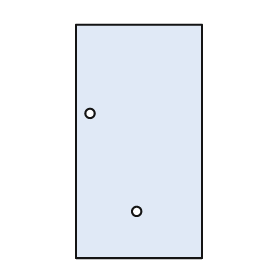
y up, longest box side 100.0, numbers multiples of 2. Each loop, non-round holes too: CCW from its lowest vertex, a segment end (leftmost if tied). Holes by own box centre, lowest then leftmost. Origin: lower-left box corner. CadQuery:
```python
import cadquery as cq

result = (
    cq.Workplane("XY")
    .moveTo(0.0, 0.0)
    .lineTo(54.0, 0.0)
    .lineTo(54.0, 100.0)
    .lineTo(0.0, 100.0)
    .close()
    .moveTo(26.0, 20.0)
    .circle(2.0)
    .moveTo(6.0, 62.0)
    .circle(2.0)
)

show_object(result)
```